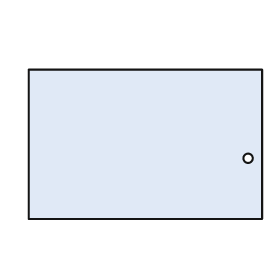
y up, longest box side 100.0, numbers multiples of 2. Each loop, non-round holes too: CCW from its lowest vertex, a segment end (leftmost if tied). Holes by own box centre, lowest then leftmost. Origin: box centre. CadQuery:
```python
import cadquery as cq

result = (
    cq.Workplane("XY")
    .moveTo(-50.0, -32.0)
    .lineTo(50.0, -32.0)
    .lineTo(50.0, 32.0)
    .lineTo(-50.0, 32.0)
    .close()
    .moveTo(44.0, -6.0)
    .circle(2.0)
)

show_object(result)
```